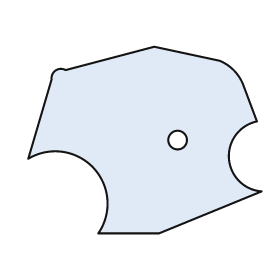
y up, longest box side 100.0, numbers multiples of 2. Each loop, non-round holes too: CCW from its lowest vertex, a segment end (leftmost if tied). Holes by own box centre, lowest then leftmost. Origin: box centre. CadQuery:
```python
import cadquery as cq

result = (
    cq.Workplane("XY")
    .moveTo(-20.0, -40.0)
    .lineTo(6.0, -40.0)
    .lineTo(50.0, -22.0)
    .threePointArc((36.0, -8.0), (48.0, 8.0))
    .lineTo(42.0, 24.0)
    .threePointArc((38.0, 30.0), (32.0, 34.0))
    .lineTo(4.0, 40.0)
    .lineTo(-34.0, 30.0)
    .threePointArc((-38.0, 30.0), (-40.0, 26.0))
    .lineTo(-50.0, -8.0)
    .threePointArc((-22.0, -12.0), (-20.0, -40.0))
    .close()
    .moveTo(14.0, 0.0)
    .circle(4.0)
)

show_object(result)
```